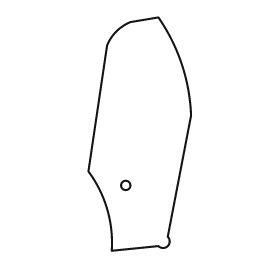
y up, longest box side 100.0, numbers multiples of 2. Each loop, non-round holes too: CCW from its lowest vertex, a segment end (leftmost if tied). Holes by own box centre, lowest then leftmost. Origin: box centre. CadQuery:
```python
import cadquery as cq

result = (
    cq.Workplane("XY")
    .moveTo(-12.0, -50.0)
    .lineTo(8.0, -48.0)
    .threePointArc((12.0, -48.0), (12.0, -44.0))
    .lineTo(22.0, 8.0)
    .threePointArc((18.0, 30.0), (8.0, 50.0))
    .lineTo(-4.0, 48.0)
    .threePointArc((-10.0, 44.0), (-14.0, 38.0))
    .lineTo(-22.0, -16.0)
    .threePointArc((-14.0, -32.0), (-12.0, -50.0))
    .close()
    .moveTo(-6.0, -22.0)
    .circle(2.0)
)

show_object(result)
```